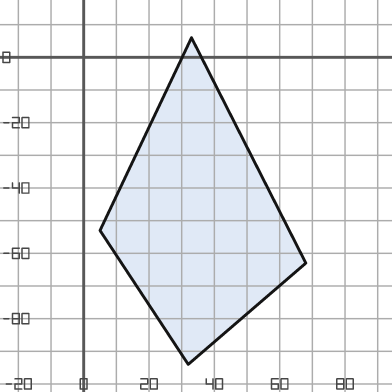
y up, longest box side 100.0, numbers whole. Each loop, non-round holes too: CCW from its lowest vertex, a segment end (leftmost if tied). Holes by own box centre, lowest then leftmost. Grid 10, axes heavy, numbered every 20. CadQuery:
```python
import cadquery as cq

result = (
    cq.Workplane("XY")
    .moveTo(32.0, -94.0)
    .lineTo(68.0, -63.0)
    .lineTo(33.0, 6.0)
    .lineTo(5.0, -53.0)
    .close()
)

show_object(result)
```